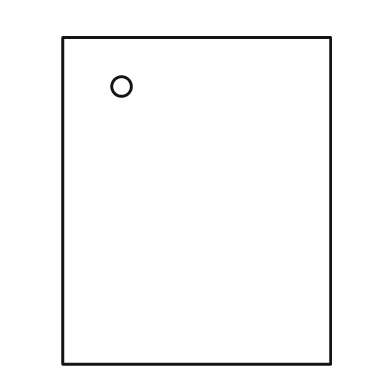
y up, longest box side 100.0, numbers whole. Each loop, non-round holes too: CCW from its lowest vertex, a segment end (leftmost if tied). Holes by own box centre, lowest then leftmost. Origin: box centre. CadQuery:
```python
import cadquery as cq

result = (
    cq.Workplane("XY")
    .moveTo(-41.0, -50.0)
    .lineTo(41.0, -50.0)
    .lineTo(41.0, 50.0)
    .lineTo(-41.0, 50.0)
    .close()
    .moveTo(-23.0, 35.0)
    .circle(3.0)
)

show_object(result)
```